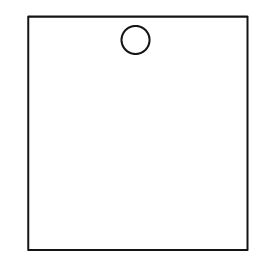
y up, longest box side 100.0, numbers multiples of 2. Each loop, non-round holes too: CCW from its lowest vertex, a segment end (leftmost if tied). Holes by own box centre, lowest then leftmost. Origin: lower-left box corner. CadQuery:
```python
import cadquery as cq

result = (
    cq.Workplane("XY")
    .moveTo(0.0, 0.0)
    .lineTo(94.0, 0.0)
    .lineTo(94.0, 100.0)
    .lineTo(0.0, 100.0)
    .close()
    .moveTo(46.0, 90.0)
    .circle(6.0)
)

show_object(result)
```